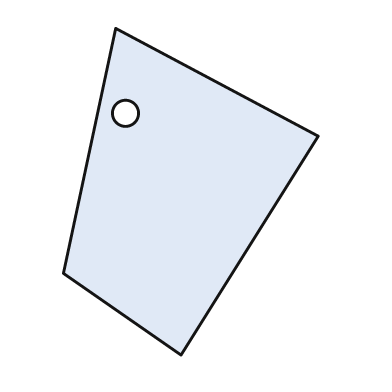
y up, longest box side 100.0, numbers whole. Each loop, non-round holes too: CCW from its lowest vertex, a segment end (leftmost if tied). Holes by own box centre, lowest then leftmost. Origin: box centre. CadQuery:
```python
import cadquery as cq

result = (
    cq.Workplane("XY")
    .moveTo(-3.0, -50.0)
    .lineTo(39.0, 17.0)
    .lineTo(-23.0, 50.0)
    .lineTo(-39.0, -25.0)
    .close()
    .moveTo(-20.0, 24.0)
    .circle(4.0)
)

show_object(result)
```